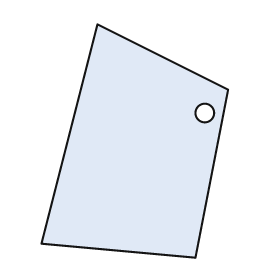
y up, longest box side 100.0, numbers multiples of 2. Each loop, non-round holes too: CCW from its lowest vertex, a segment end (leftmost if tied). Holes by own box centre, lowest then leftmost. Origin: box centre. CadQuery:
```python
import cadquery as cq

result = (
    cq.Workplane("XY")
    .moveTo(26.0, -50.0)
    .lineTo(40.0, 22.0)
    .lineTo(-16.0, 50.0)
    .lineTo(-40.0, -44.0)
    .close()
    .moveTo(30.0, 12.0)
    .circle(4.0)
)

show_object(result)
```